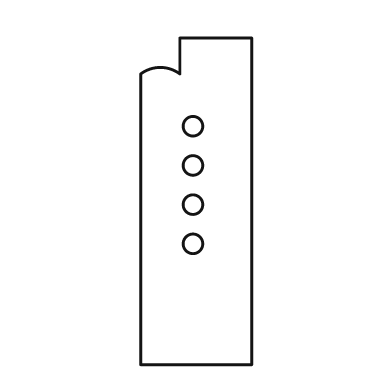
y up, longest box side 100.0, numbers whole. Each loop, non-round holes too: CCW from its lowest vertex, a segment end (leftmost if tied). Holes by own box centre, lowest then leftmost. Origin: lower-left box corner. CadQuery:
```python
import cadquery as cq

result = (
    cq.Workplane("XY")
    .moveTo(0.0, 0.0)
    .lineTo(34.0, 0.0)
    .lineTo(34.0, 100.0)
    .lineTo(12.0, 100.0)
    .lineTo(12.0, 89.0)
    .threePointArc((6.0, 91.0), (0.0, 89.0))
    .close()
    .moveTo(16.0, 37.0)
    .circle(3.0)
    .moveTo(16.0, 49.0)
    .circle(3.0)
    .moveTo(16.0, 61.0)
    .circle(3.0)
    .moveTo(16.0, 73.0)
    .circle(3.0)
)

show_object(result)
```